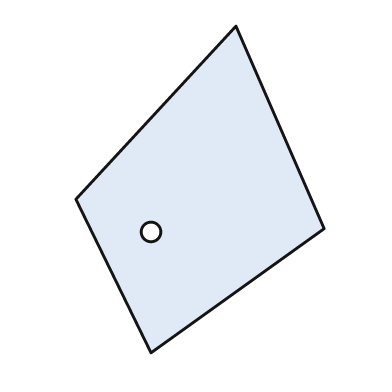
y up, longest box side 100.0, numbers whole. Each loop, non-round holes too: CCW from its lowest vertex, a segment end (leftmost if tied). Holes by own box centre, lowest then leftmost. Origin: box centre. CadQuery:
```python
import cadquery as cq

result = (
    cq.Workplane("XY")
    .moveTo(-15.0, -50.0)
    .lineTo(38.0, -12.0)
    .lineTo(11.0, 50.0)
    .lineTo(-38.0, -3.0)
    .close()
    .moveTo(-15.0, -13.0)
    .circle(3.0)
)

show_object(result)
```